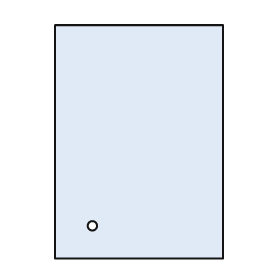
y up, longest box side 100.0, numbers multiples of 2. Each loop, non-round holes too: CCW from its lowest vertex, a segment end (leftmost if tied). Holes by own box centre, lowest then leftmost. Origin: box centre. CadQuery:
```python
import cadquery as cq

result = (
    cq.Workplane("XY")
    .moveTo(-36.0, -50.0)
    .lineTo(36.0, -50.0)
    .lineTo(36.0, 50.0)
    .lineTo(-36.0, 50.0)
    .close()
    .moveTo(-20.0, -36.0)
    .circle(2.0)
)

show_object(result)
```